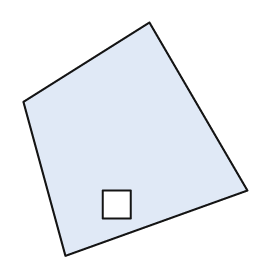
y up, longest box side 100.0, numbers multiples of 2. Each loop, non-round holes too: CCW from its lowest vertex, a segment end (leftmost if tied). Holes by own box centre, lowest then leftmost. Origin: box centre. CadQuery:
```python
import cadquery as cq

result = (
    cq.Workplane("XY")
    .moveTo(-30.0, -50.0)
    .lineTo(48.0, -22.0)
    .lineTo(6.0, 50.0)
    .lineTo(-48.0, 16.0)
    .close()
    .moveTo(-14.0, -34.0)
    .lineTo(-2.0, -34.0)
    .lineTo(-2.0, -22.0)
    .lineTo(-14.0, -22.0)
    .close()
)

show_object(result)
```